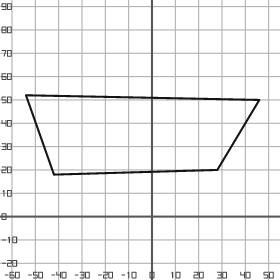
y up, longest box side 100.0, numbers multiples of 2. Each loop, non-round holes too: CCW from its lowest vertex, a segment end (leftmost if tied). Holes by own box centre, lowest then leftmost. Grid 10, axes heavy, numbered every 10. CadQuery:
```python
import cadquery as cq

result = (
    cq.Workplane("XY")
    .moveTo(-42.0, 18.0)
    .lineTo(28.0, 20.0)
    .lineTo(46.0, 50.0)
    .lineTo(-54.0, 52.0)
    .close()
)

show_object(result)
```